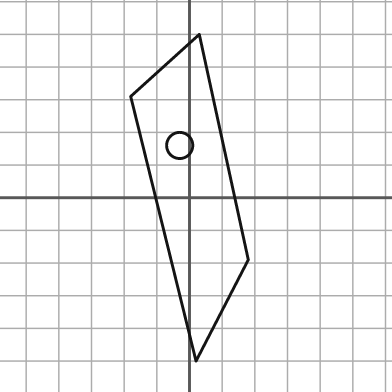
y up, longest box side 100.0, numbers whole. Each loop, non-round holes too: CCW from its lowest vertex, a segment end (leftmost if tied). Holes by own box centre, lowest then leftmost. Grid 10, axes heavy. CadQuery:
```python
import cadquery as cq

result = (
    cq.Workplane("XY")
    .moveTo(2.0, -50.0)
    .lineTo(18.0, -19.0)
    .lineTo(3.0, 50.0)
    .lineTo(-18.0, 31.0)
    .close()
    .moveTo(-3.0, 16.0)
    .circle(4.0)
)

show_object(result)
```